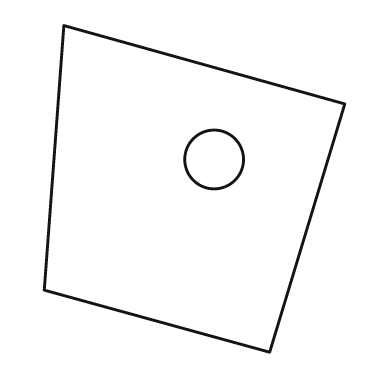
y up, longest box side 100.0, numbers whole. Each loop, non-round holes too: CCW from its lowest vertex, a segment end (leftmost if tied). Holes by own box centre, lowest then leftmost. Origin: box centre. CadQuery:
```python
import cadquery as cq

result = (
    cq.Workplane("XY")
    .moveTo(23.0, -50.0)
    .lineTo(46.0, 26.0)
    .lineTo(-40.0, 50.0)
    .lineTo(-46.0, -31.0)
    .close()
    .moveTo(6.0, 9.0)
    .circle(9.0)
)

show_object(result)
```